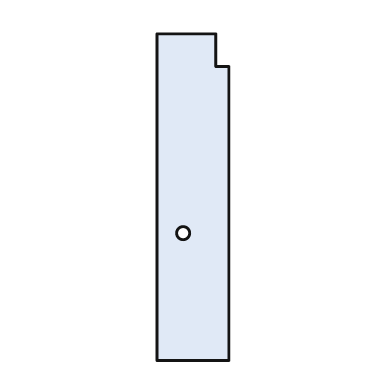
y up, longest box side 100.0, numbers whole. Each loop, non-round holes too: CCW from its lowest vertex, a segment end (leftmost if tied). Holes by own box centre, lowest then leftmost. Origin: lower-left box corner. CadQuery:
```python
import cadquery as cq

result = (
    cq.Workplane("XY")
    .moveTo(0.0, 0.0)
    .lineTo(22.0, 0.0)
    .lineTo(22.0, 90.0)
    .lineTo(18.0, 90.0)
    .lineTo(18.0, 100.0)
    .lineTo(0.0, 100.0)
    .close()
    .moveTo(8.0, 39.0)
    .circle(2.0)
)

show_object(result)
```